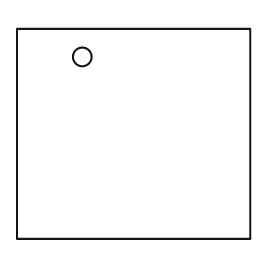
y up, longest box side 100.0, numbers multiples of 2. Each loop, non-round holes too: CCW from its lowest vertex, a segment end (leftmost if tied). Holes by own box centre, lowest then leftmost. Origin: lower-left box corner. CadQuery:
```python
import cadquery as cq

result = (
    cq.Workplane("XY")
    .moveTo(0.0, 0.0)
    .lineTo(100.0, 0.0)
    .lineTo(100.0, 90.0)
    .lineTo(0.0, 90.0)
    .close()
    .moveTo(28.0, 78.0)
    .circle(4.0)
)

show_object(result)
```